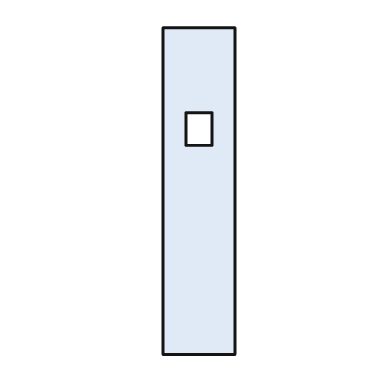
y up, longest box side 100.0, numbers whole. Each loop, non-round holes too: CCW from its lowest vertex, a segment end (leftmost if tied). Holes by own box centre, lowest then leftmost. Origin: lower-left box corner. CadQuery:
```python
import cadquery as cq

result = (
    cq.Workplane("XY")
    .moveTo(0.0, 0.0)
    .lineTo(22.0, 0.0)
    .lineTo(22.0, 100.0)
    .lineTo(0.0, 100.0)
    .close()
    .moveTo(7.0, 64.0)
    .lineTo(15.0, 64.0)
    .lineTo(15.0, 74.0)
    .lineTo(7.0, 74.0)
    .close()
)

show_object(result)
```